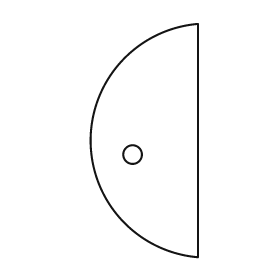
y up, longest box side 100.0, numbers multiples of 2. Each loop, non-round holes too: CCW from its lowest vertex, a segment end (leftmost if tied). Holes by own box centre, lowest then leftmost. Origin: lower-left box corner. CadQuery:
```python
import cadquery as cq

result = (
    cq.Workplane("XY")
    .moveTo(46.0, 0.0)
    .lineTo(46.0, 100.0)
    .threePointArc((0.0, 50.0), (46.0, 0.0))
    .close()
    .moveTo(18.0, 44.0)
    .circle(4.0)
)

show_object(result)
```